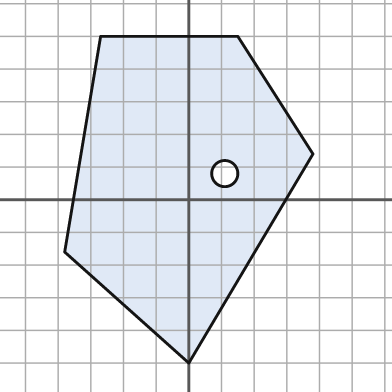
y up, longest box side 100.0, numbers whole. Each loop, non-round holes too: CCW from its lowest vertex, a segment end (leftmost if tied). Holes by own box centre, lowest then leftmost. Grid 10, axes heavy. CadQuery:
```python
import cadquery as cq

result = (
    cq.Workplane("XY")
    .moveTo(0.0, -50.0)
    .lineTo(38.0, 14.0)
    .lineTo(15.0, 50.0)
    .lineTo(-27.0, 50.0)
    .lineTo(-38.0, -16.0)
    .close()
    .moveTo(11.0, 8.0)
    .circle(4.0)
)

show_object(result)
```